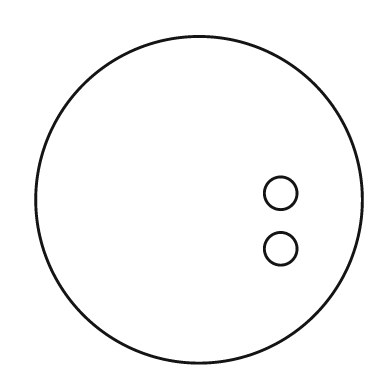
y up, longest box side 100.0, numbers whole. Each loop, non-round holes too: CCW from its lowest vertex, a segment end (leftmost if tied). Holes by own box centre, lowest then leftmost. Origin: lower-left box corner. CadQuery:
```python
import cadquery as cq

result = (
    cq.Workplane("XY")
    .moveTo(50.0, 50.0)
    .circle(50.0)
    .moveTo(75.0, 35.0)
    .circle(5.0)
    .moveTo(75.0, 52.0)
    .circle(5.0)
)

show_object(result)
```